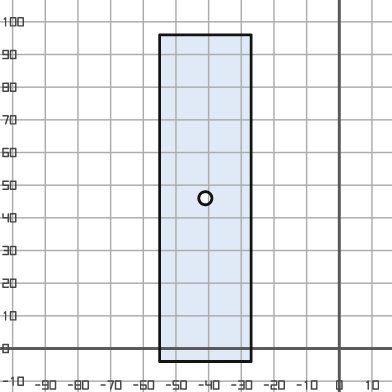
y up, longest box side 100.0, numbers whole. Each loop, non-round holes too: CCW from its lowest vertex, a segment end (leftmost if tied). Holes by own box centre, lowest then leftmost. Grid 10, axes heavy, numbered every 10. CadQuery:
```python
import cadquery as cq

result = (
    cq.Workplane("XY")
    .moveTo(-55.0, -4.0)
    .lineTo(-27.0, -4.0)
    .lineTo(-27.0, 96.0)
    .lineTo(-55.0, 96.0)
    .close()
    .moveTo(-41.0, 46.0)
    .circle(2.0)
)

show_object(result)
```